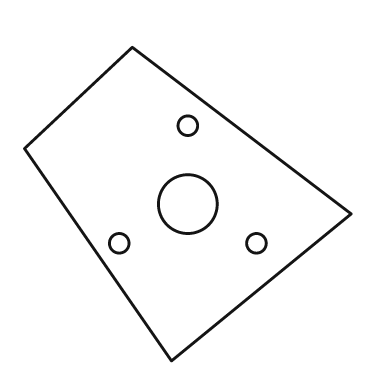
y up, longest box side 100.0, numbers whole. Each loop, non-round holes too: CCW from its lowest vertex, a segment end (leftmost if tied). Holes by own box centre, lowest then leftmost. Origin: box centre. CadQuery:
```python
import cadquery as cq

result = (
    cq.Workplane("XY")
    .moveTo(-5.0, -48.0)
    .lineTo(50.0, -3.0)
    .lineTo(-17.0, 48.0)
    .lineTo(-50.0, 17.0)
    .close()
    .moveTo(-21.0, -12.0)
    .circle(3.0)
    .moveTo(21.0, -12.0)
    .circle(3.0)
    .moveTo(0.0, 0.0)
    .circle(9.0)
    .moveTo(0.0, 24.0)
    .circle(3.0)
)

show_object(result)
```